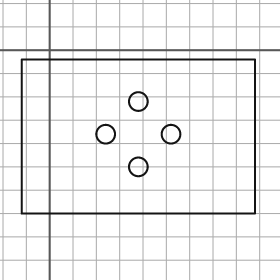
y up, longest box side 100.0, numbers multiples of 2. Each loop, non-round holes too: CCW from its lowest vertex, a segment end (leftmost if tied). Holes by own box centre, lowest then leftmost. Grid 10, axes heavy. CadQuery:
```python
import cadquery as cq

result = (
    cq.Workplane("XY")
    .moveTo(-12.0, -70.0)
    .lineTo(88.0, -70.0)
    .lineTo(88.0, -4.0)
    .lineTo(-12.0, -4.0)
    .close()
    .moveTo(38.0, -50.0)
    .circle(4.0)
    .moveTo(24.0, -36.0)
    .circle(4.0)
    .moveTo(52.0, -36.0)
    .circle(4.0)
    .moveTo(38.0, -22.0)
    .circle(4.0)
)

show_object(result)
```